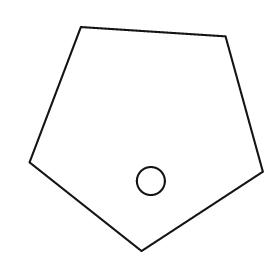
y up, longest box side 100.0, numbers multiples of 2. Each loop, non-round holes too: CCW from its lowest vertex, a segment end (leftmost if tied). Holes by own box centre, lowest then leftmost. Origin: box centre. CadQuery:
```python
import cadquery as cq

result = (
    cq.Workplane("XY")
    .moveTo(-2.0, -48.0)
    .lineTo(50.0, -14.0)
    .lineTo(34.0, 44.0)
    .lineTo(-28.0, 48.0)
    .lineTo(-50.0, -10.0)
    .close()
    .moveTo(2.0, -18.0)
    .circle(6.0)
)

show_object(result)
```